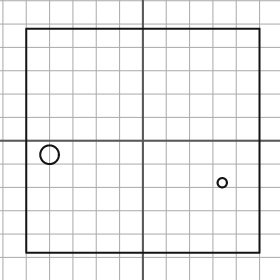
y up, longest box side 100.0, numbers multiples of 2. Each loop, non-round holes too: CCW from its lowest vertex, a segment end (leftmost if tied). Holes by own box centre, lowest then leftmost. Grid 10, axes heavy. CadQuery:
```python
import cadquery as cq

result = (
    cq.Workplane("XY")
    .moveTo(-50.0, -48.0)
    .lineTo(50.0, -48.0)
    .lineTo(50.0, 48.0)
    .lineTo(-50.0, 48.0)
    .close()
    .moveTo(34.0, -18.0)
    .circle(2.0)
    .moveTo(-40.0, -6.0)
    .circle(4.0)
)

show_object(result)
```